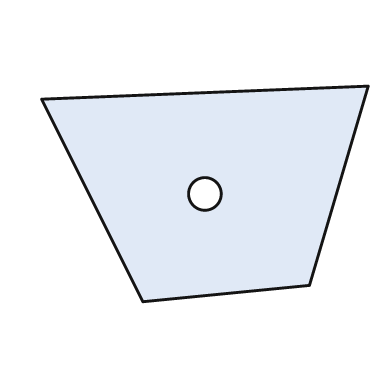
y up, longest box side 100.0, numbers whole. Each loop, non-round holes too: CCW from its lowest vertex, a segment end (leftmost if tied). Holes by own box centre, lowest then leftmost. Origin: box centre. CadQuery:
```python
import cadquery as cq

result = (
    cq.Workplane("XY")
    .moveTo(-19.0, -33.0)
    .lineTo(32.0, -28.0)
    .lineTo(50.0, 33.0)
    .lineTo(-50.0, 29.0)
    .close()
    .moveTo(0.0, 0.0)
    .circle(5.0)
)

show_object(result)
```